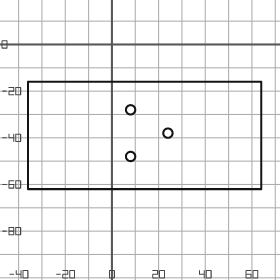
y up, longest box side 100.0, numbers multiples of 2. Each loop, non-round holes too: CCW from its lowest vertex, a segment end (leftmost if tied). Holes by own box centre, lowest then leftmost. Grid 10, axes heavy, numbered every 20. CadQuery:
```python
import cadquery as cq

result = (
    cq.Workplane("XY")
    .moveTo(-36.0, -62.0)
    .lineTo(64.0, -62.0)
    .lineTo(64.0, -16.0)
    .lineTo(-36.0, -16.0)
    .close()
    .moveTo(8.0, -48.0)
    .circle(2.0)
    .moveTo(24.0, -38.0)
    .circle(2.0)
    .moveTo(8.0, -28.0)
    .circle(2.0)
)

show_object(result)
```